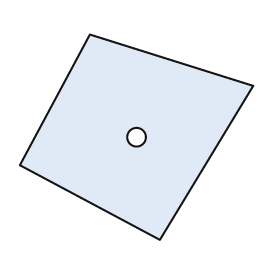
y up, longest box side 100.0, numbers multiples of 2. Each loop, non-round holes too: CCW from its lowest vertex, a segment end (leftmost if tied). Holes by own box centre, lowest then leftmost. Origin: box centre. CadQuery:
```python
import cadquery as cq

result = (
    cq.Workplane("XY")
    .moveTo(10.0, -44.0)
    .lineTo(50.0, 22.0)
    .lineTo(-20.0, 44.0)
    .lineTo(-50.0, -12.0)
    .close()
    .moveTo(0.0, 0.0)
    .circle(4.0)
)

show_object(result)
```